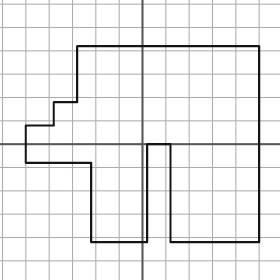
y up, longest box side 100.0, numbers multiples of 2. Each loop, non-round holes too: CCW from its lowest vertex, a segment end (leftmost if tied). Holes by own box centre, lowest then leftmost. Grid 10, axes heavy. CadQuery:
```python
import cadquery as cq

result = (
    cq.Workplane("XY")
    .moveTo(-22.0, -42.0)
    .lineTo(2.0, -42.0)
    .lineTo(2.0, 0.0)
    .lineTo(12.0, 0.0)
    .lineTo(12.0, -42.0)
    .lineTo(50.0, -42.0)
    .lineTo(50.0, 42.0)
    .lineTo(-28.0, 42.0)
    .lineTo(-28.0, 18.0)
    .lineTo(-38.0, 18.0)
    .lineTo(-38.0, 8.0)
    .lineTo(-50.0, 8.0)
    .lineTo(-50.0, -8.0)
    .lineTo(-22.0, -8.0)
    .close()
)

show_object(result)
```